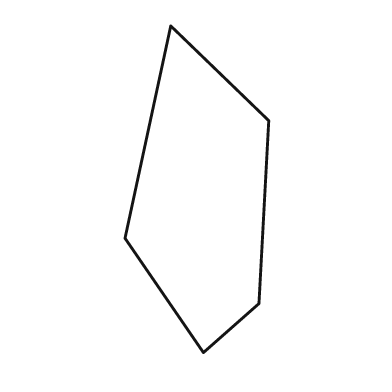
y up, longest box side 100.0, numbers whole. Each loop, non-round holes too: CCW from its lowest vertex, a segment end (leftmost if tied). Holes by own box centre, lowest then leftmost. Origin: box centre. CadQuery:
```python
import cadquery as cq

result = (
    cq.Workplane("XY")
    .moveTo(2.0, -50.0)
    .lineTo(19.0, -35.0)
    .lineTo(22.0, 21.0)
    .lineTo(-8.0, 50.0)
    .lineTo(-22.0, -15.0)
    .close()
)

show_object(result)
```